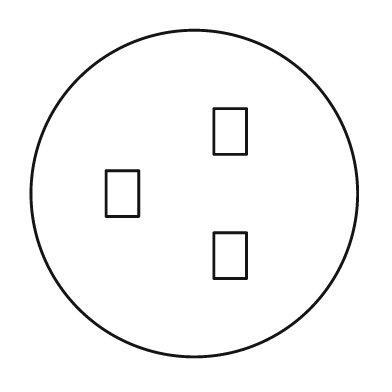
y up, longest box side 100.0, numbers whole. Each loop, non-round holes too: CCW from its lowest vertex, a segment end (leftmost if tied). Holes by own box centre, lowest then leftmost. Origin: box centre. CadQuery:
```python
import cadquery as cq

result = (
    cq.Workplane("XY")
    .moveTo(0.0, 0.0)
    .circle(50.0)
    .moveTo(6.0, -26.0)
    .lineTo(16.0, -26.0)
    .lineTo(16.0, -12.0)
    .lineTo(6.0, -12.0)
    .close()
    .moveTo(-27.0, -7.0)
    .lineTo(-17.0, -7.0)
    .lineTo(-17.0, 7.0)
    .lineTo(-27.0, 7.0)
    .close()
    .moveTo(6.0, 12.0)
    .lineTo(16.0, 12.0)
    .lineTo(16.0, 26.0)
    .lineTo(6.0, 26.0)
    .close()
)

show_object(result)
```